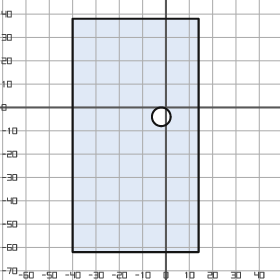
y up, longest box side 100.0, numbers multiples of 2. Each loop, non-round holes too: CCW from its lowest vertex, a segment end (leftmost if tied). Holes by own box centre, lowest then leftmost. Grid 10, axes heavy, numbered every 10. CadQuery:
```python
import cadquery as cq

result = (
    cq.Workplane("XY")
    .moveTo(-40.0, -62.0)
    .lineTo(14.0, -62.0)
    .lineTo(14.0, 38.0)
    .lineTo(-40.0, 38.0)
    .close()
    .moveTo(-2.0, -4.0)
    .circle(4.0)
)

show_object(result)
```